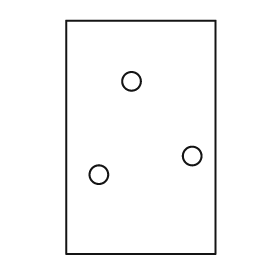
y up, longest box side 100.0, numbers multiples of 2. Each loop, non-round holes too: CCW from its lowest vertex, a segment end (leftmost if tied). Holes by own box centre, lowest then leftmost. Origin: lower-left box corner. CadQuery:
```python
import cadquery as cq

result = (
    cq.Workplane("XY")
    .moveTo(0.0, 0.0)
    .lineTo(64.0, 0.0)
    .lineTo(64.0, 100.0)
    .lineTo(0.0, 100.0)
    .close()
    .moveTo(14.0, 34.0)
    .circle(4.0)
    .moveTo(54.0, 42.0)
    .circle(4.0)
    .moveTo(28.0, 74.0)
    .circle(4.0)
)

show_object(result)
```